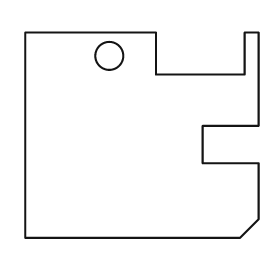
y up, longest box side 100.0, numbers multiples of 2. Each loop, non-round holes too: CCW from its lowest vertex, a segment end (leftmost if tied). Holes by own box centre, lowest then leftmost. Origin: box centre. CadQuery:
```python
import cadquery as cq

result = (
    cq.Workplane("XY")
    .moveTo(-50.0, -44.0)
    .lineTo(42.0, -44.0)
    .lineTo(50.0, -36.0)
    .lineTo(50.0, -12.0)
    .lineTo(26.0, -12.0)
    .lineTo(26.0, 4.0)
    .lineTo(50.0, 4.0)
    .lineTo(50.0, 44.0)
    .lineTo(44.0, 44.0)
    .lineTo(44.0, 26.0)
    .lineTo(6.0, 26.0)
    .lineTo(6.0, 44.0)
    .lineTo(-50.0, 44.0)
    .close()
    .moveTo(-14.0, 34.0)
    .circle(6.0)
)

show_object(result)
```